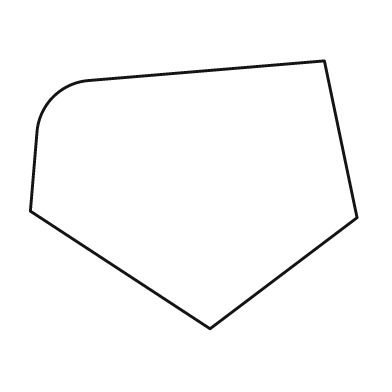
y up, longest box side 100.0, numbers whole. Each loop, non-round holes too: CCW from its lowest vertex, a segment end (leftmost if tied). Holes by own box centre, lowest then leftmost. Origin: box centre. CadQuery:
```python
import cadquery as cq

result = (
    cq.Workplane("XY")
    .moveTo(5.0, -41.0)
    .lineTo(50.0, -7.0)
    .lineTo(40.0, 41.0)
    .lineTo(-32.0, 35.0)
    .threePointArc((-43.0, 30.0), (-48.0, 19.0))
    .lineTo(-50.0, -5.0)
    .close()
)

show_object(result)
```